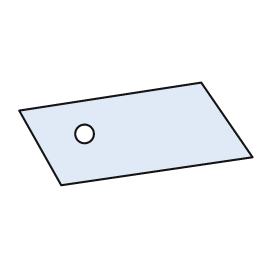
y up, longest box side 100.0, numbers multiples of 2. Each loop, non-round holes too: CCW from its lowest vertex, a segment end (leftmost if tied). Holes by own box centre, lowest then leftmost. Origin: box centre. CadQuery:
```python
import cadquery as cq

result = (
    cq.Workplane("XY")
    .moveTo(-32.0, -22.0)
    .lineTo(50.0, -10.0)
    .lineTo(28.0, 22.0)
    .lineTo(-50.0, 10.0)
    .close()
    .moveTo(-22.0, 0.0)
    .circle(4.0)
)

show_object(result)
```